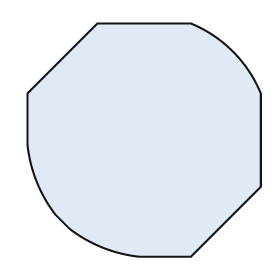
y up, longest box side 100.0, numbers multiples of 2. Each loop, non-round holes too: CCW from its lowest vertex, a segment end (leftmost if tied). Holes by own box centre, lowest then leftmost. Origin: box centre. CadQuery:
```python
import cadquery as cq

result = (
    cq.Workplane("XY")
    .moveTo(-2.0, -50.0)
    .lineTo(20.0, -50.0)
    .lineTo(50.0, -20.0)
    .lineTo(50.0, 20.0)
    .threePointArc((38.0, 38.0), (20.0, 50.0))
    .lineTo(-20.0, 50.0)
    .lineTo(-50.0, 20.0)
    .lineTo(-50.0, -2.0)
    .threePointArc((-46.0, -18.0), (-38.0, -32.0))
    .lineTo(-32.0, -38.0)
    .threePointArc((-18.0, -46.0), (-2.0, -50.0))
    .close()
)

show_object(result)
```